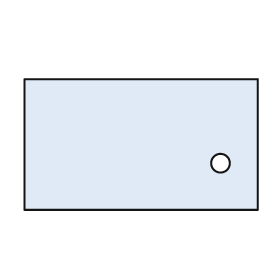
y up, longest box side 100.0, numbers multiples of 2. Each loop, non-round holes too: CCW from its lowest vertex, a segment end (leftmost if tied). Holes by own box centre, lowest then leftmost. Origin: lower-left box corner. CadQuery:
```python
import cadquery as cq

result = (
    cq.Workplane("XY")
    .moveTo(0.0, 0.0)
    .lineTo(100.0, 0.0)
    .lineTo(100.0, 56.0)
    .lineTo(0.0, 56.0)
    .close()
    .moveTo(84.0, 20.0)
    .circle(4.0)
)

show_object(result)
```